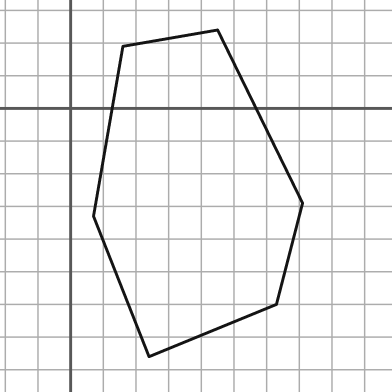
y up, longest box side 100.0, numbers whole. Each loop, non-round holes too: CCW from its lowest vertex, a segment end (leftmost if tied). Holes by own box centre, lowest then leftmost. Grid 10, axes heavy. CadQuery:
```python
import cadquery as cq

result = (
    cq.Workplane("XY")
    .moveTo(24.0, -76.0)
    .lineTo(63.0, -60.0)
    .lineTo(71.0, -29.0)
    .lineTo(45.0, 24.0)
    .lineTo(16.0, 19.0)
    .lineTo(7.0, -33.0)
    .close()
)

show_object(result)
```